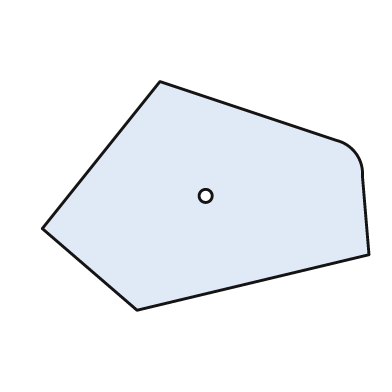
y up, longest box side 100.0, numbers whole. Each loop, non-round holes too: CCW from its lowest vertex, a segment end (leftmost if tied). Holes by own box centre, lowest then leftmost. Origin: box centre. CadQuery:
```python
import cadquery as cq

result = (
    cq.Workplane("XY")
    .moveTo(-21.0, -35.0)
    .lineTo(50.0, -18.0)
    .lineTo(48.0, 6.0)
    .threePointArc((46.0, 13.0), (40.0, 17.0))
    .lineTo(-14.0, 35.0)
    .lineTo(-50.0, -10.0)
    .close()
    .moveTo(0.0, 0.0)
    .circle(2.0)
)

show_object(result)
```